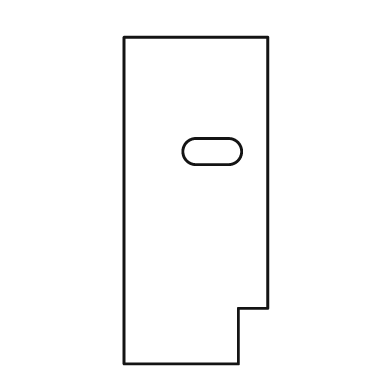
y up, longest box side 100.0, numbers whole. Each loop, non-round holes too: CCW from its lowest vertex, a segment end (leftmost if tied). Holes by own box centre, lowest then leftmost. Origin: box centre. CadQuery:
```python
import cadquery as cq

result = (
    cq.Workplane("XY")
    .moveTo(-22.0, -50.0)
    .lineTo(13.0, -50.0)
    .lineTo(13.0, -33.0)
    .lineTo(22.0, -33.0)
    .lineTo(22.0, 50.0)
    .lineTo(-22.0, 50.0)
    .close()
    .moveTo(0.0, 11.0)
    .lineTo(10.0, 11.0)
    .threePointArc((14.0, 15.0), (10.0, 19.0))
    .lineTo(0.0, 19.0)
    .threePointArc((-4.0, 15.0), (0.0, 11.0))
    .close()
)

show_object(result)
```